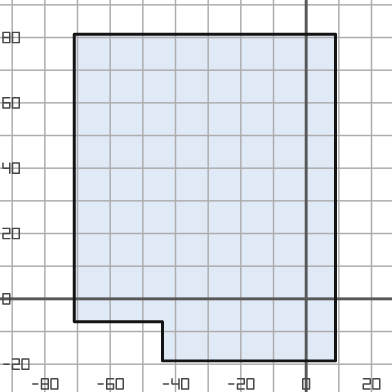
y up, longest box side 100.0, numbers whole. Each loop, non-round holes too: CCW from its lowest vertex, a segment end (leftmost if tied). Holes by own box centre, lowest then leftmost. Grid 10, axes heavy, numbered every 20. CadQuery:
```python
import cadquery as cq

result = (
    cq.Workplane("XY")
    .moveTo(-44.0, -19.0)
    .lineTo(9.0, -19.0)
    .lineTo(9.0, 81.0)
    .lineTo(-71.0, 81.0)
    .lineTo(-71.0, -7.0)
    .lineTo(-44.0, -7.0)
    .close()
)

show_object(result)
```